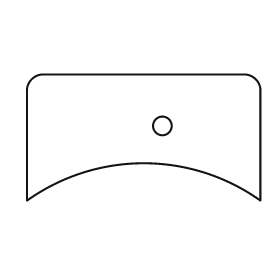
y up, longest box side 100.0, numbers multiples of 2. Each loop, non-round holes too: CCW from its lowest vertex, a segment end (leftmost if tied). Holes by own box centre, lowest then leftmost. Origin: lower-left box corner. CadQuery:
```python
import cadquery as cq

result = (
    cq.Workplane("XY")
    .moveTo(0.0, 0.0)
    .threePointArc((50.0, 16.0), (100.0, 0.0))
    .lineTo(100.0, 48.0)
    .threePointArc((98.0, 52.0), (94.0, 54.0))
    .lineTo(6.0, 54.0)
    .threePointArc((2.0, 52.0), (0.0, 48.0))
    .close()
    .moveTo(58.0, 32.0)
    .circle(4.0)
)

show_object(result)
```